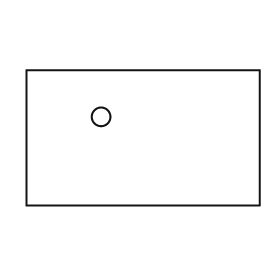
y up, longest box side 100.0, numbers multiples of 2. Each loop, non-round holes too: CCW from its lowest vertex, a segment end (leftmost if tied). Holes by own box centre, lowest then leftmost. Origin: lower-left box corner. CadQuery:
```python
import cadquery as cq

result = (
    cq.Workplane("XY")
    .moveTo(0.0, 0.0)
    .lineTo(100.0, 0.0)
    .lineTo(100.0, 58.0)
    .lineTo(0.0, 58.0)
    .close()
    .moveTo(32.0, 38.0)
    .circle(4.0)
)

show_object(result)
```